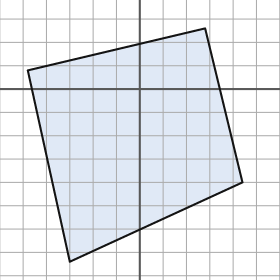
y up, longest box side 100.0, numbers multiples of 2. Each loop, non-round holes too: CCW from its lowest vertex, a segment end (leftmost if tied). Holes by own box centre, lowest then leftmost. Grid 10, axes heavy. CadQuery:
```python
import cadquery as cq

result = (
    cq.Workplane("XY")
    .moveTo(-30.0, -74.0)
    .lineTo(44.0, -40.0)
    .lineTo(28.0, 26.0)
    .lineTo(-48.0, 8.0)
    .close()
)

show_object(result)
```